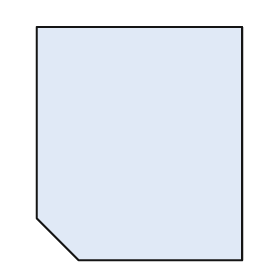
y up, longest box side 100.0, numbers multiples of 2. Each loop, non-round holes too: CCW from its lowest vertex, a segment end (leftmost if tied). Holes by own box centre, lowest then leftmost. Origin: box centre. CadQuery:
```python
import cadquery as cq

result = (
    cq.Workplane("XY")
    .moveTo(-26.0, -50.0)
    .lineTo(44.0, -50.0)
    .lineTo(44.0, 50.0)
    .lineTo(-44.0, 50.0)
    .lineTo(-44.0, -32.0)
    .close()
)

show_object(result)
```